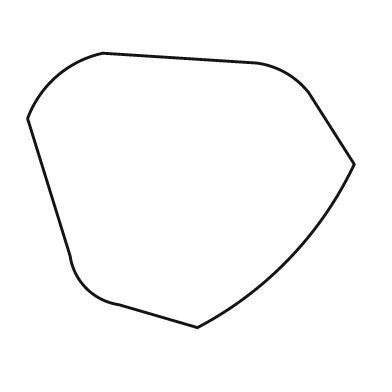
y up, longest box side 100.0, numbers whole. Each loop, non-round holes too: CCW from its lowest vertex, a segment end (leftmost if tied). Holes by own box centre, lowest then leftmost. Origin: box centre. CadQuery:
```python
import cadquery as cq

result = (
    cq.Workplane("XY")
    .moveTo(2.0, -42.0)
    .threePointArc((30.0, -21.0), (50.0, 8.0))
    .lineTo(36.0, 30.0)
    .threePointArc((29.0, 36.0), (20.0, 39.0))
    .lineTo(-27.0, 42.0)
    .threePointArc((-41.0, 35.0), (-50.0, 22.0))
    .lineTo(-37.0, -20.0)
    .threePointArc((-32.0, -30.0), (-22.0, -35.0))
    .close()
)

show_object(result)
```